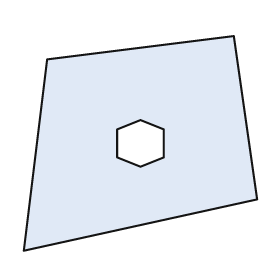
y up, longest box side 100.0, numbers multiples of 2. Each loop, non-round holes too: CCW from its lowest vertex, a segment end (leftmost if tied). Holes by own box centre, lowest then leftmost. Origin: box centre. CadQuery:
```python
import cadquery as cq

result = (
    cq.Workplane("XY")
    .moveTo(-50.0, -46.0)
    .lineTo(50.0, -24.0)
    .lineTo(40.0, 46.0)
    .lineTo(-40.0, 36.0)
    .close()
    .moveTo(0.0, -10.0)
    .lineTo(10.0, -6.0)
    .lineTo(10.0, 6.0)
    .lineTo(0.0, 10.0)
    .lineTo(-10.0, 6.0)
    .lineTo(-10.0, -6.0)
    .close()
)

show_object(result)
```